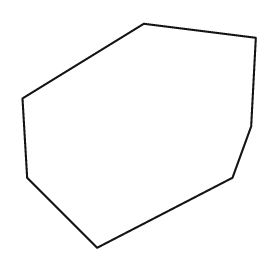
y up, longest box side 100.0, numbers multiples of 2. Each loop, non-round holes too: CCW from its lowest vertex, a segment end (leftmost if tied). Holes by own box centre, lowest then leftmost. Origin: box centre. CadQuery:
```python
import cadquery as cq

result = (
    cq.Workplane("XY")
    .moveTo(-18.0, -48.0)
    .lineTo(40.0, -18.0)
    .lineTo(48.0, 4.0)
    .lineTo(50.0, 42.0)
    .lineTo(2.0, 48.0)
    .lineTo(-50.0, 16.0)
    .lineTo(-48.0, -18.0)
    .close()
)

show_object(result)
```